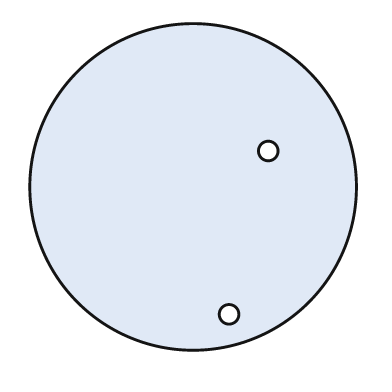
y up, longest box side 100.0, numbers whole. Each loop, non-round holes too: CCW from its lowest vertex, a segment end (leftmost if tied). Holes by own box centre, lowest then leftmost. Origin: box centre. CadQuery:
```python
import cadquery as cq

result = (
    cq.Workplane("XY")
    .moveTo(0.0, 0.0)
    .circle(50.0)
    .moveTo(11.0, -39.0)
    .circle(3.0)
    .moveTo(23.0, 11.0)
    .circle(3.0)
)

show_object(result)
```